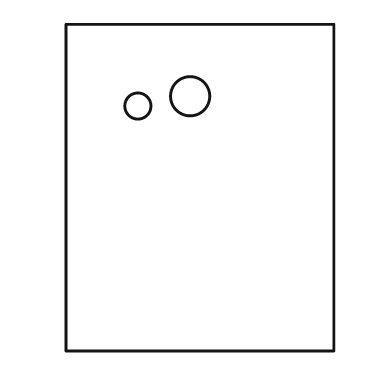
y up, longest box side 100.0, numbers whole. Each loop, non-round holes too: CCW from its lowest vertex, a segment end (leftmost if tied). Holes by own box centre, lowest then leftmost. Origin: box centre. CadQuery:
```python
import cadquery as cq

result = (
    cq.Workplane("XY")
    .moveTo(-41.0, -50.0)
    .lineTo(41.0, -50.0)
    .lineTo(41.0, 50.0)
    .lineTo(-41.0, 50.0)
    .close()
    .moveTo(-19.0, 25.0)
    .circle(4.0)
    .moveTo(-3.0, 28.0)
    .circle(6.0)
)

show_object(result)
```